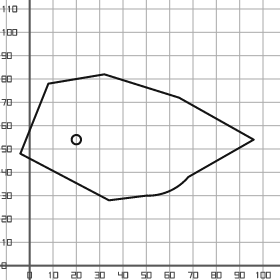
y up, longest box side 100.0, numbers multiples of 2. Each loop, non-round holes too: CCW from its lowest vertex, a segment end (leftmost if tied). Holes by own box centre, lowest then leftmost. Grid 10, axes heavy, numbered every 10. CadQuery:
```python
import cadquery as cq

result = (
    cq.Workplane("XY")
    .moveTo(34.0, 28.0)
    .lineTo(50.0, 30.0)
    .threePointArc((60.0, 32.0), (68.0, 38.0))
    .lineTo(96.0, 54.0)
    .lineTo(64.0, 72.0)
    .lineTo(32.0, 82.0)
    .lineTo(8.0, 78.0)
    .lineTo(-4.0, 48.0)
    .close()
    .moveTo(20.0, 54.0)
    .circle(2.0)
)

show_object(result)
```